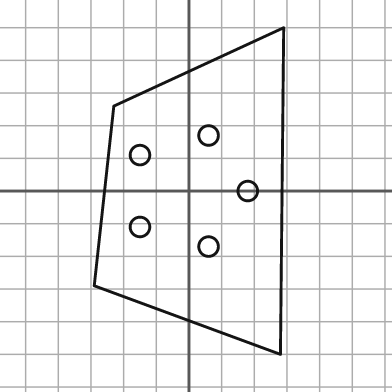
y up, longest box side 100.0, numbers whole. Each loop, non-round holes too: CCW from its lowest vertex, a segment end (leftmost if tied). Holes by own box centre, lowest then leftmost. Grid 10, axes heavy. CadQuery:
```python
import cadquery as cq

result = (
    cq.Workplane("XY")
    .moveTo(28.0, -50.0)
    .lineTo(29.0, 50.0)
    .lineTo(-23.0, 26.0)
    .lineTo(-29.0, -29.0)
    .close()
    .moveTo(6.0, -17.0)
    .circle(3.0)
    .moveTo(-15.0, -11.0)
    .circle(3.0)
    .moveTo(18.0, 0.0)
    .circle(3.0)
    .moveTo(-15.0, 11.0)
    .circle(3.0)
    .moveTo(6.0, 17.0)
    .circle(3.0)
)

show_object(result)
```